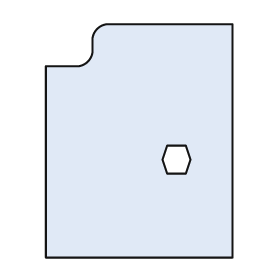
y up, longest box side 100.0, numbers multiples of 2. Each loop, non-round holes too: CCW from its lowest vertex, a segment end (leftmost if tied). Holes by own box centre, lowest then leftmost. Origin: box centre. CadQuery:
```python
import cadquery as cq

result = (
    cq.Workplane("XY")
    .moveTo(-40.0, -50.0)
    .lineTo(40.0, -50.0)
    .lineTo(40.0, 50.0)
    .lineTo(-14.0, 50.0)
    .threePointArc((-18.0, 48.0), (-20.0, 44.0))
    .lineTo(-20.0, 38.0)
    .threePointArc((-22.0, 34.0), (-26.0, 32.0))
    .lineTo(-40.0, 32.0)
    .close()
    .moveTo(12.0, -14.0)
    .lineTo(20.0, -14.0)
    .lineTo(22.0, -8.0)
    .lineTo(20.0, -2.0)
    .lineTo(12.0, -2.0)
    .lineTo(10.0, -8.0)
    .close()
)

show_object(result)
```